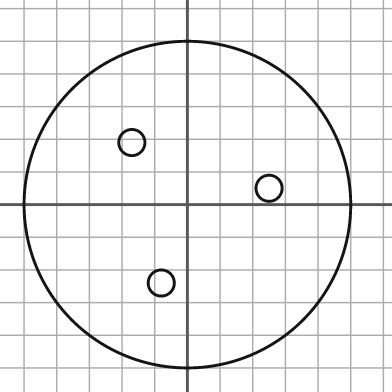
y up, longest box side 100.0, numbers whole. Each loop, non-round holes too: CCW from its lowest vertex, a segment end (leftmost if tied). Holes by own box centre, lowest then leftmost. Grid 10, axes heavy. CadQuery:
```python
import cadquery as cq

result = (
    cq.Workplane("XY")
    .moveTo(0.0, 0.0)
    .circle(50.0)
    .moveTo(-8.0, -24.0)
    .circle(4.0)
    .moveTo(25.0, 5.0)
    .circle(4.0)
    .moveTo(-17.0, 19.0)
    .circle(4.0)
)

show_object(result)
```